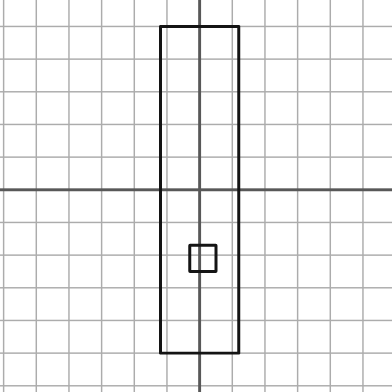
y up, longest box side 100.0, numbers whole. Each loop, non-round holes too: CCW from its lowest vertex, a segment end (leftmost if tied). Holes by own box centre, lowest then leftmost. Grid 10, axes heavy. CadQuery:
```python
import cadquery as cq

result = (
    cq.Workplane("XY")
    .moveTo(-12.0, -50.0)
    .lineTo(12.0, -50.0)
    .lineTo(12.0, 50.0)
    .lineTo(-12.0, 50.0)
    .close()
    .moveTo(-3.0, -25.0)
    .lineTo(5.0, -25.0)
    .lineTo(5.0, -17.0)
    .lineTo(-3.0, -17.0)
    .close()
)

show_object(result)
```